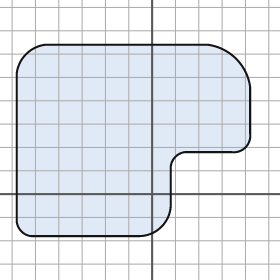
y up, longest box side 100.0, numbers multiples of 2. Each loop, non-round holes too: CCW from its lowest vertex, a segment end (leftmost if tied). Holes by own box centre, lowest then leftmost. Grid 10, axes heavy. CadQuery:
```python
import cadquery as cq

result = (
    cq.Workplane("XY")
    .moveTo(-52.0, -18.0)
    .lineTo(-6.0, -18.0)
    .threePointArc((4.0, -14.0), (8.0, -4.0))
    .lineTo(8.0, 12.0)
    .threePointArc((10.0, 16.0), (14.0, 18.0))
    .lineTo(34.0, 18.0)
    .threePointArc((40.0, 20.0), (42.0, 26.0))
    .lineTo(42.0, 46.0)
    .threePointArc((36.0, 58.0), (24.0, 64.0))
    .lineTo(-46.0, 64.0)
    .threePointArc((-54.0, 60.0), (-58.0, 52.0))
    .lineTo(-58.0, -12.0)
    .threePointArc((-56.0, -16.0), (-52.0, -18.0))
    .close()
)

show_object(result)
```